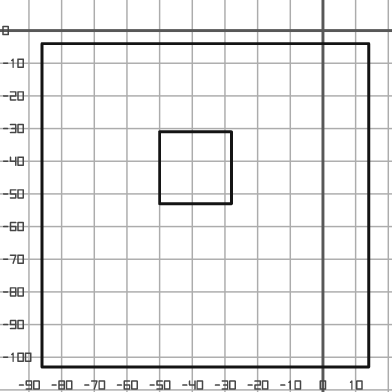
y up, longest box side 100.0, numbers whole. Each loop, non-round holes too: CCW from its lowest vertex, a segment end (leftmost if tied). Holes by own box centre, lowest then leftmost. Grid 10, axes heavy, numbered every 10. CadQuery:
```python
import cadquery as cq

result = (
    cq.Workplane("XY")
    .moveTo(-86.0, -103.0)
    .lineTo(14.0, -103.0)
    .lineTo(14.0, -4.0)
    .lineTo(-86.0, -4.0)
    .close()
    .moveTo(-50.0, -53.0)
    .lineTo(-28.0, -53.0)
    .lineTo(-28.0, -31.0)
    .lineTo(-50.0, -31.0)
    .close()
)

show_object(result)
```